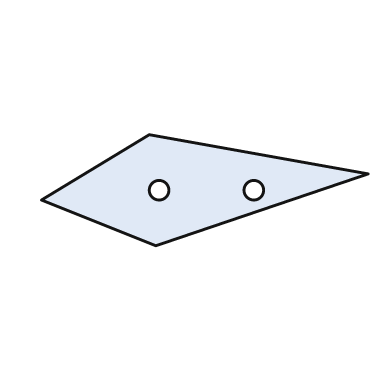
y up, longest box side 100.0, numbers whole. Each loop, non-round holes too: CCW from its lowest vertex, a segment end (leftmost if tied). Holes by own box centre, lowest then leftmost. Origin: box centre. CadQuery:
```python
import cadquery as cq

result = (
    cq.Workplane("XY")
    .moveTo(-15.0, -17.0)
    .lineTo(50.0, 5.0)
    .lineTo(-17.0, 17.0)
    .lineTo(-50.0, -3.0)
    .close()
    .moveTo(-14.0, 0.0)
    .circle(3.0)
    .moveTo(15.0, 0.0)
    .circle(3.0)
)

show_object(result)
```